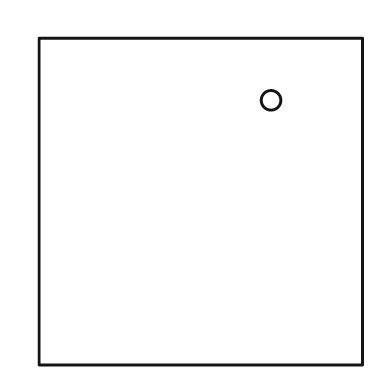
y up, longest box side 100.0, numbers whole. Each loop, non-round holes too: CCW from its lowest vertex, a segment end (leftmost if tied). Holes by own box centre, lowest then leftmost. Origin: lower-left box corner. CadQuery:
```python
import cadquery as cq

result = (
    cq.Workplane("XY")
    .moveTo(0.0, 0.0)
    .lineTo(99.0, 0.0)
    .lineTo(99.0, 100.0)
    .lineTo(0.0, 100.0)
    .close()
    .moveTo(71.0, 81.0)
    .circle(3.0)
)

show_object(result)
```